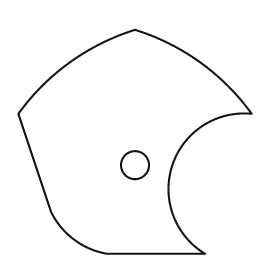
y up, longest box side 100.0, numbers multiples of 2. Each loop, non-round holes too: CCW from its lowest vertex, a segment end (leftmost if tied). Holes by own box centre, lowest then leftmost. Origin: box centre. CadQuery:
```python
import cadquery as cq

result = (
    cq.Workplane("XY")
    .moveTo(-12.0, -48.0)
    .lineTo(30.0, -48.0)
    .threePointArc((16.0, -10.0), (50.0, 12.0))
    .threePointArc((28.0, 34.0), (0.0, 48.0))
    .threePointArc((-28.0, 34.0), (-50.0, 12.0))
    .lineTo(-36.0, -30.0)
    .threePointArc((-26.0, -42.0), (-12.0, -48.0))
    .close()
    .moveTo(0.0, -10.0)
    .circle(6.0)
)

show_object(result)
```